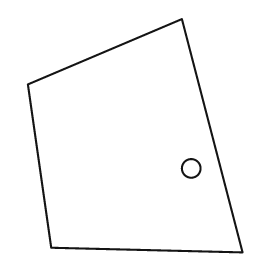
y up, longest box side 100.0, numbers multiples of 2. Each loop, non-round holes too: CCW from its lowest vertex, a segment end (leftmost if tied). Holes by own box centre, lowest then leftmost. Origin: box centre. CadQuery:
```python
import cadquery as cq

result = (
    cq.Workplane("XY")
    .moveTo(46.0, -50.0)
    .lineTo(20.0, 50.0)
    .lineTo(-46.0, 22.0)
    .lineTo(-36.0, -48.0)
    .close()
    .moveTo(24.0, -14.0)
    .circle(4.0)
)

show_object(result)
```